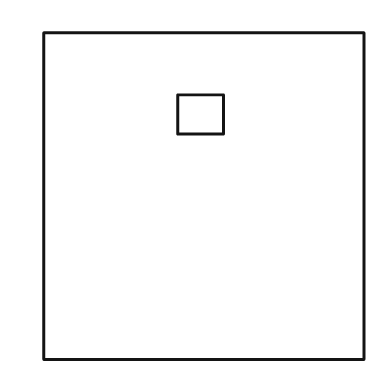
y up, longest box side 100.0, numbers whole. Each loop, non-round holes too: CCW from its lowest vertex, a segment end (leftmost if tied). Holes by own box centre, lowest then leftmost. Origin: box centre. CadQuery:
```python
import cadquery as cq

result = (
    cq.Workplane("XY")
    .moveTo(-49.0, -50.0)
    .lineTo(49.0, -50.0)
    .lineTo(49.0, 50.0)
    .lineTo(-49.0, 50.0)
    .close()
    .moveTo(-8.0, 19.0)
    .lineTo(6.0, 19.0)
    .lineTo(6.0, 31.0)
    .lineTo(-8.0, 31.0)
    .close()
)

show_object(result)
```